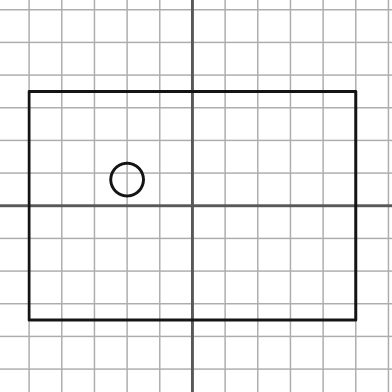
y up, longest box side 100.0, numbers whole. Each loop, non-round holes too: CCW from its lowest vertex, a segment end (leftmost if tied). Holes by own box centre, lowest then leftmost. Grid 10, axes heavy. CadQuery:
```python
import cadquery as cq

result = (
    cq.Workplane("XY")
    .moveTo(-50.0, -35.0)
    .lineTo(50.0, -35.0)
    .lineTo(50.0, 35.0)
    .lineTo(-50.0, 35.0)
    .close()
    .moveTo(-20.0, 8.0)
    .circle(5.0)
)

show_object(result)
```